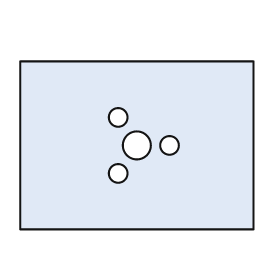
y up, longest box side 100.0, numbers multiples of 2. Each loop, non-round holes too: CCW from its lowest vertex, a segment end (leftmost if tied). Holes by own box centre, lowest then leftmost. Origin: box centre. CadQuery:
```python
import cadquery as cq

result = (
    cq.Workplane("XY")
    .moveTo(-50.0, -36.0)
    .lineTo(50.0, -36.0)
    .lineTo(50.0, 36.0)
    .lineTo(-50.0, 36.0)
    .close()
    .moveTo(-8.0, -12.0)
    .circle(4.0)
    .moveTo(0.0, 0.0)
    .circle(6.0)
    .moveTo(14.0, 0.0)
    .circle(4.0)
    .moveTo(-8.0, 12.0)
    .circle(4.0)
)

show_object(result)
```